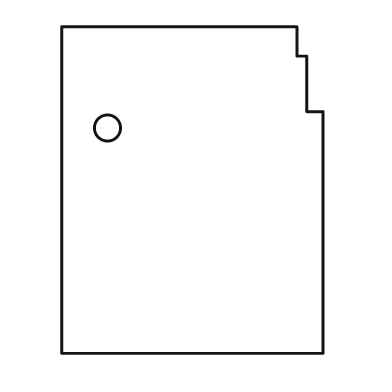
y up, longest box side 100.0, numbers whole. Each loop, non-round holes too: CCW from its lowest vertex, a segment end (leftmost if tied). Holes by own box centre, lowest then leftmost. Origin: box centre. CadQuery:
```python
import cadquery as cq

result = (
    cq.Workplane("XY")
    .moveTo(-40.0, -50.0)
    .lineTo(40.0, -50.0)
    .lineTo(40.0, 24.0)
    .lineTo(35.0, 24.0)
    .lineTo(35.0, 41.0)
    .lineTo(32.0, 41.0)
    .lineTo(32.0, 50.0)
    .lineTo(-40.0, 50.0)
    .close()
    .moveTo(-26.0, 19.0)
    .circle(4.0)
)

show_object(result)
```